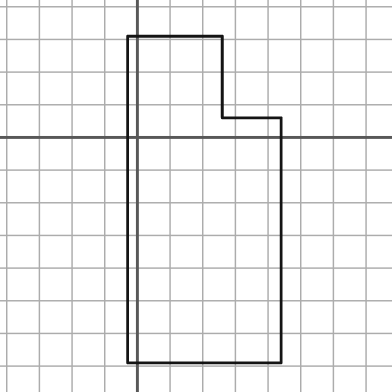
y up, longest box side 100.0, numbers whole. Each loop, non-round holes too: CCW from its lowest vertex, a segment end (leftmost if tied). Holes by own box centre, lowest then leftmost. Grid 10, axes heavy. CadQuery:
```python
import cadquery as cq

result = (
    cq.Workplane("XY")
    .moveTo(-3.0, -69.0)
    .lineTo(44.0, -69.0)
    .lineTo(44.0, 6.0)
    .lineTo(26.0, 6.0)
    .lineTo(26.0, 31.0)
    .lineTo(-3.0, 31.0)
    .close()
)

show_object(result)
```